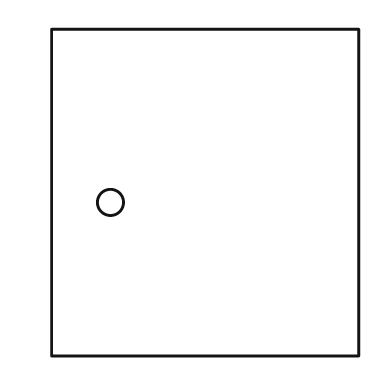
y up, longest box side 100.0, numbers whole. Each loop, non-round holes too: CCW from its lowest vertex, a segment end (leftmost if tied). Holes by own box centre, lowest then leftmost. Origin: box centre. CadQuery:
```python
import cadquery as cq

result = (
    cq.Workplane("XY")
    .moveTo(-47.0, -50.0)
    .lineTo(47.0, -50.0)
    .lineTo(47.0, 50.0)
    .lineTo(-47.0, 50.0)
    .close()
    .moveTo(-29.0, -3.0)
    .circle(4.0)
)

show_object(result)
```